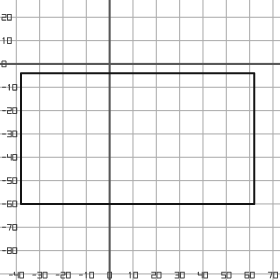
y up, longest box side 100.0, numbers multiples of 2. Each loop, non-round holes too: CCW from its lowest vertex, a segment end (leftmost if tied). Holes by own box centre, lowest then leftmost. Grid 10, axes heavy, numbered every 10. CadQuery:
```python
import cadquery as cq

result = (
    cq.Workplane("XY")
    .moveTo(-38.0, -60.0)
    .lineTo(62.0, -60.0)
    .lineTo(62.0, -4.0)
    .lineTo(-38.0, -4.0)
    .close()
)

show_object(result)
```